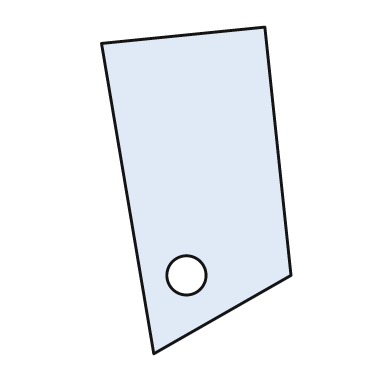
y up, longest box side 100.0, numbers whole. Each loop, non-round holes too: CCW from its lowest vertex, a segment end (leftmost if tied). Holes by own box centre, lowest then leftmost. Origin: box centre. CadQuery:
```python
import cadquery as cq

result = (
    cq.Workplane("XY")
    .moveTo(-13.0, -50.0)
    .lineTo(29.0, -26.0)
    .lineTo(21.0, 50.0)
    .lineTo(-29.0, 45.0)
    .close()
    .moveTo(-3.0, -26.0)
    .circle(6.0)
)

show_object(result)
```